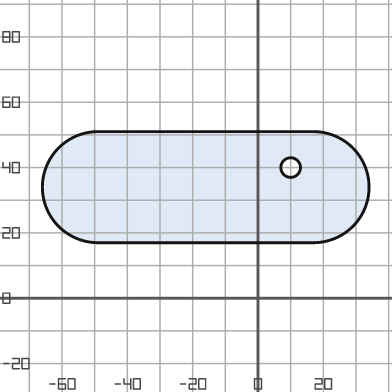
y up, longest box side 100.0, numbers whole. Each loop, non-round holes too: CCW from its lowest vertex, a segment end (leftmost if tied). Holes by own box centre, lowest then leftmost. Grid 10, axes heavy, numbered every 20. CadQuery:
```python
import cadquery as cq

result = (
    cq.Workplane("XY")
    .moveTo(-49.0, 17.0)
    .lineTo(17.0, 17.0)
    .threePointArc((34.0, 34.0), (17.0, 51.0))
    .lineTo(-49.0, 51.0)
    .threePointArc((-66.0, 34.0), (-49.0, 17.0))
    .close()
    .moveTo(10.0, 40.0)
    .circle(3.0)
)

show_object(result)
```